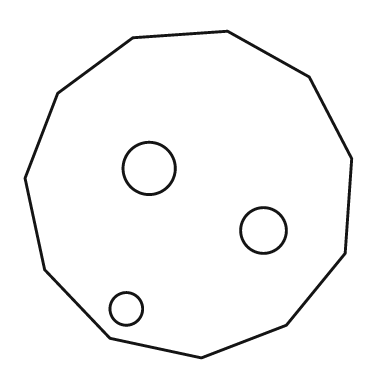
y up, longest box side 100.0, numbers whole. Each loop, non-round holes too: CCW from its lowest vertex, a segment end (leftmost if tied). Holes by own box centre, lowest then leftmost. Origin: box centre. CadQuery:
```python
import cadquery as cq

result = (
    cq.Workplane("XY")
    .moveTo(4.0, -50.0)
    .lineTo(30.0, -40.0)
    .lineTo(48.0, -18.0)
    .lineTo(50.0, 11.0)
    .lineTo(37.0, 36.0)
    .lineTo(12.0, 50.0)
    .lineTo(-17.0, 48.0)
    .lineTo(-40.0, 31.0)
    .lineTo(-50.0, 5.0)
    .lineTo(-44.0, -23.0)
    .lineTo(-24.0, -44.0)
    .close()
    .moveTo(-19.0, -35.0)
    .circle(5.0)
    .moveTo(23.0, -11.0)
    .circle(7.0)
    .moveTo(-12.0, 8.0)
    .circle(8.0)
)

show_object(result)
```